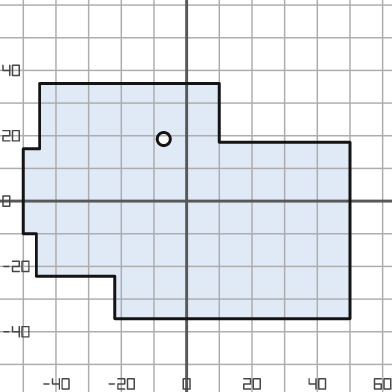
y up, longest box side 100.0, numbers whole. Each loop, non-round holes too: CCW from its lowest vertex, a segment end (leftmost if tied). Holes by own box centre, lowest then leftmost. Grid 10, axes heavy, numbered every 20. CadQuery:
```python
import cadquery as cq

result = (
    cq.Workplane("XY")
    .moveTo(-22.0, -36.0)
    .lineTo(50.0, -36.0)
    .lineTo(50.0, 18.0)
    .lineTo(10.0, 18.0)
    .lineTo(10.0, 36.0)
    .lineTo(-45.0, 36.0)
    .lineTo(-45.0, 16.0)
    .lineTo(-50.0, 16.0)
    .lineTo(-50.0, -10.0)
    .lineTo(-46.0, -10.0)
    .lineTo(-46.0, -23.0)
    .lineTo(-22.0, -23.0)
    .close()
    .moveTo(-7.0, 19.0)
    .circle(2.0)
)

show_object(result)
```